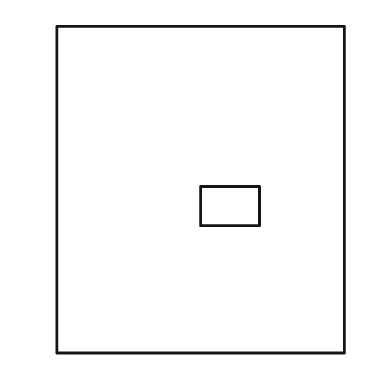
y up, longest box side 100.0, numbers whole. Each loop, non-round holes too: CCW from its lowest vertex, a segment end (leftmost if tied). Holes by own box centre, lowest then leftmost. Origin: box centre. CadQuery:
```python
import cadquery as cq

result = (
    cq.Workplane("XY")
    .moveTo(-44.0, -50.0)
    .lineTo(44.0, -50.0)
    .lineTo(44.0, 50.0)
    .lineTo(-44.0, 50.0)
    .close()
    .moveTo(0.0, -11.0)
    .lineTo(18.0, -11.0)
    .lineTo(18.0, 1.0)
    .lineTo(0.0, 1.0)
    .close()
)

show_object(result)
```